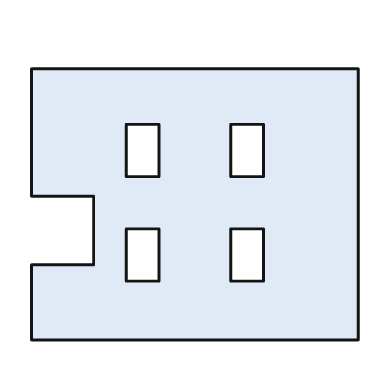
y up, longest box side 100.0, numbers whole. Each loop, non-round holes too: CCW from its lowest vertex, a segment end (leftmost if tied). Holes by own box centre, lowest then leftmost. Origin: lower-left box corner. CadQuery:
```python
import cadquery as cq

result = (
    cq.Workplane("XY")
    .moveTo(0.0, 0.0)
    .lineTo(100.0, 0.0)
    .lineTo(100.0, 83.0)
    .lineTo(0.0, 83.0)
    .lineTo(0.0, 44.0)
    .lineTo(19.0, 44.0)
    .lineTo(19.0, 23.0)
    .lineTo(0.0, 23.0)
    .close()
    .moveTo(29.0, 18.0)
    .lineTo(39.0, 18.0)
    .lineTo(39.0, 34.0)
    .lineTo(29.0, 34.0)
    .close()
    .moveTo(61.0, 18.0)
    .lineTo(71.0, 18.0)
    .lineTo(71.0, 34.0)
    .lineTo(61.0, 34.0)
    .close()
    .moveTo(29.0, 50.0)
    .lineTo(39.0, 50.0)
    .lineTo(39.0, 66.0)
    .lineTo(29.0, 66.0)
    .close()
    .moveTo(61.0, 50.0)
    .lineTo(71.0, 50.0)
    .lineTo(71.0, 66.0)
    .lineTo(61.0, 66.0)
    .close()
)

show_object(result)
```